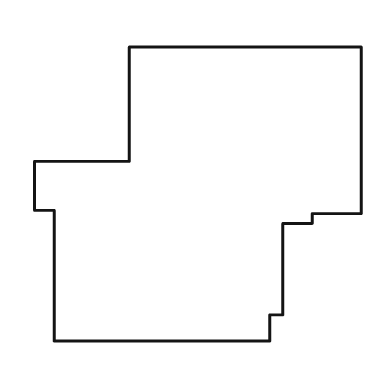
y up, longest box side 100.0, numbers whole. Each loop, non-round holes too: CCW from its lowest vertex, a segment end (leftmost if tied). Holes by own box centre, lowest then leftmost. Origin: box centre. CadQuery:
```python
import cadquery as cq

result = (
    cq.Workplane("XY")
    .moveTo(-44.0, -45.0)
    .lineTo(22.0, -45.0)
    .lineTo(22.0, -37.0)
    .lineTo(26.0, -37.0)
    .lineTo(26.0, -9.0)
    .lineTo(35.0, -9.0)
    .lineTo(35.0, -6.0)
    .lineTo(50.0, -6.0)
    .lineTo(50.0, 45.0)
    .lineTo(-21.0, 45.0)
    .lineTo(-21.0, 10.0)
    .lineTo(-50.0, 10.0)
    .lineTo(-50.0, -5.0)
    .lineTo(-44.0, -5.0)
    .close()
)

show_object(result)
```